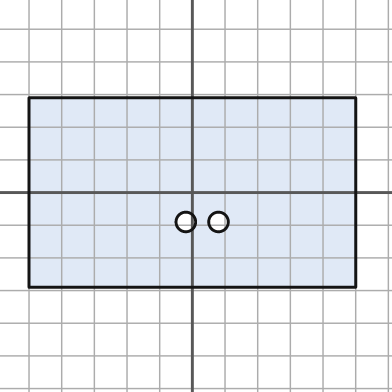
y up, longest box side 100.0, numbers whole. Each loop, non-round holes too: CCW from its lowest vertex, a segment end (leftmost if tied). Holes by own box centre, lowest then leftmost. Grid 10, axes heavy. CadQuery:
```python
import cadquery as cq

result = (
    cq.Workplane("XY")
    .moveTo(-50.0, -29.0)
    .lineTo(50.0, -29.0)
    .lineTo(50.0, 29.0)
    .lineTo(-50.0, 29.0)
    .close()
    .moveTo(-2.0, -9.0)
    .circle(3.0)
    .moveTo(8.0, -9.0)
    .circle(3.0)
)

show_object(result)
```